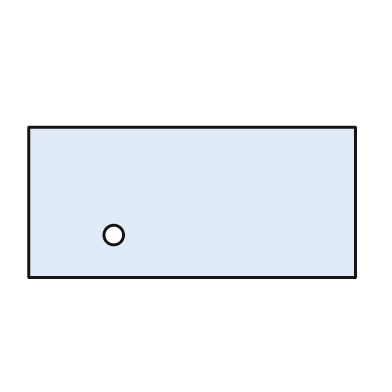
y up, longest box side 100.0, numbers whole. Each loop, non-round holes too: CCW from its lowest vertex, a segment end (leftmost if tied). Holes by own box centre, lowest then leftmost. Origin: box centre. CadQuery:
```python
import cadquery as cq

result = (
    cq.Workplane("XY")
    .moveTo(-50.0, -23.0)
    .lineTo(50.0, -23.0)
    .lineTo(50.0, 23.0)
    .lineTo(-50.0, 23.0)
    .close()
    .moveTo(-24.0, -10.0)
    .circle(3.0)
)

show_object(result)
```